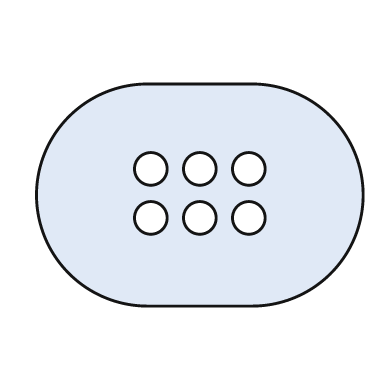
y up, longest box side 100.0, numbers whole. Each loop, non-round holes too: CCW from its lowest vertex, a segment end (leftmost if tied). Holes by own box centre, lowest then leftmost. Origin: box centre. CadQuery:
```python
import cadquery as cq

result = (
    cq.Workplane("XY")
    .moveTo(-16.0, -34.0)
    .lineTo(16.0, -34.0)
    .threePointArc((50.0, 0.0), (16.0, 34.0))
    .lineTo(-16.0, 34.0)
    .threePointArc((-50.0, 0.0), (-16.0, -34.0))
    .close()
    .moveTo(-15.0, -7.0)
    .circle(5.0)
    .moveTo(0.0, -7.0)
    .circle(5.0)
    .moveTo(15.0, -7.0)
    .circle(5.0)
    .moveTo(-15.0, 8.0)
    .circle(5.0)
    .moveTo(0.0, 8.0)
    .circle(5.0)
    .moveTo(15.0, 8.0)
    .circle(5.0)
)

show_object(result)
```